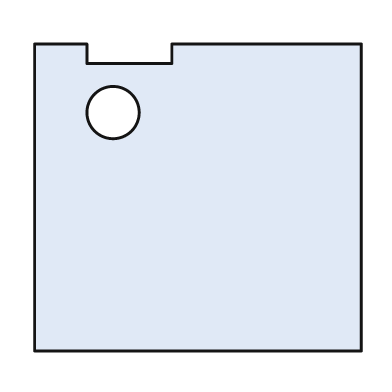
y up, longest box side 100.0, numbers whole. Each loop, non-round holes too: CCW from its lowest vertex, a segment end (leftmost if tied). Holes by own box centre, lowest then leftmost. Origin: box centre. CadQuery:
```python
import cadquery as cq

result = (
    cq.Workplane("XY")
    .moveTo(-50.0, -47.0)
    .lineTo(50.0, -47.0)
    .lineTo(50.0, 47.0)
    .lineTo(-8.0, 47.0)
    .lineTo(-8.0, 41.0)
    .lineTo(-34.0, 41.0)
    .lineTo(-34.0, 47.0)
    .lineTo(-50.0, 47.0)
    .close()
    .moveTo(-26.0, 26.0)
    .circle(8.0)
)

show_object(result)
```